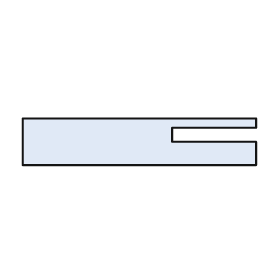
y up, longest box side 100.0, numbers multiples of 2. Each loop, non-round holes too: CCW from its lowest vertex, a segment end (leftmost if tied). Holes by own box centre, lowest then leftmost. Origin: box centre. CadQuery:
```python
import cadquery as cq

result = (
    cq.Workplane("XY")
    .moveTo(-50.0, -10.0)
    .lineTo(50.0, -10.0)
    .lineTo(50.0, 0.0)
    .lineTo(14.0, 0.0)
    .lineTo(14.0, 6.0)
    .lineTo(50.0, 6.0)
    .lineTo(50.0, 10.0)
    .lineTo(-50.0, 10.0)
    .close()
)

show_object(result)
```